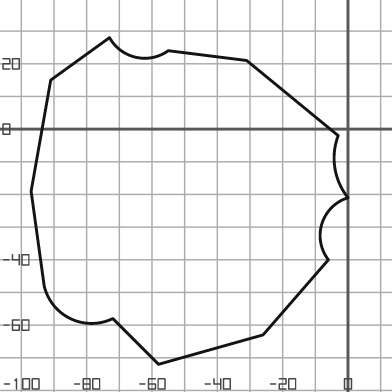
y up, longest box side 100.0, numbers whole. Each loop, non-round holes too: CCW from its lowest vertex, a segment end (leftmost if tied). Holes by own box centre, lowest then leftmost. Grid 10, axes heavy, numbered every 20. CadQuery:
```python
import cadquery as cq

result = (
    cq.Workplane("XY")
    .moveTo(-58.0, -72.0)
    .lineTo(-26.0, -63.0)
    .lineTo(-6.0, -40.0)
    .threePointArc((-8.0, -29.0), (0.0, -21.0))
    .threePointArc((-4.0, -12.0), (-3.0, -2.0))
    .lineTo(-31.0, 21.0)
    .lineTo(-55.0, 24.0)
    .threePointArc((-65.0, 22.0), (-73.0, 28.0))
    .lineTo(-91.0, 15.0)
    .lineTo(-97.0, -19.0)
    .lineTo(-93.0, -48.0)
    .threePointArc((-85.0, -58.0), (-72.0, -58.0))
    .close()
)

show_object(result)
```